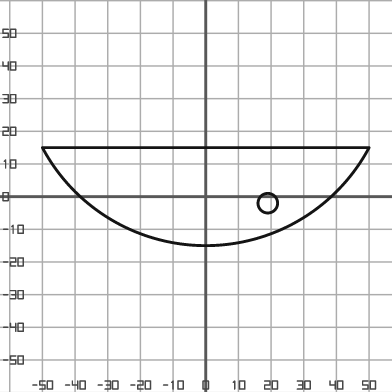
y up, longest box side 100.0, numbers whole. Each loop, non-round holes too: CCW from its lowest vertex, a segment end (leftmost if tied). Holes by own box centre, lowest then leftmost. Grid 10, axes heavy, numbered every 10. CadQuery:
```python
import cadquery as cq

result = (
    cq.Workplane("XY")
    .moveTo(-50.0, 15.0)
    .threePointArc((0.0, -15.0), (50.0, 15.0))
    .close()
    .moveTo(19.0, -2.0)
    .circle(3.0)
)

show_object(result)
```